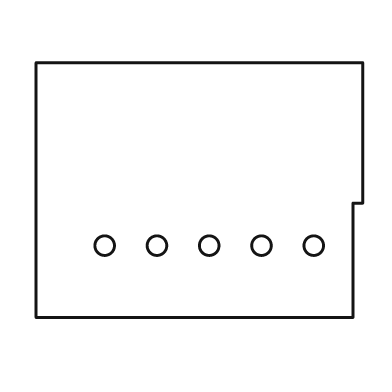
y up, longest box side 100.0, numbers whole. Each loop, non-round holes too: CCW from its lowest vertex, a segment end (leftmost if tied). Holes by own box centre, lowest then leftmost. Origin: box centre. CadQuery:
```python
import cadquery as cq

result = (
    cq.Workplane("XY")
    .moveTo(-50.0, -39.0)
    .lineTo(47.0, -39.0)
    .lineTo(47.0, -4.0)
    .lineTo(50.0, -4.0)
    .lineTo(50.0, 39.0)
    .lineTo(-50.0, 39.0)
    .close()
    .moveTo(-29.0, -17.0)
    .circle(3.0)
    .moveTo(-13.0, -17.0)
    .circle(3.0)
    .moveTo(3.0, -17.0)
    .circle(3.0)
    .moveTo(19.0, -17.0)
    .circle(3.0)
    .moveTo(35.0, -17.0)
    .circle(3.0)
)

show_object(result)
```